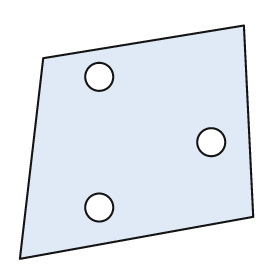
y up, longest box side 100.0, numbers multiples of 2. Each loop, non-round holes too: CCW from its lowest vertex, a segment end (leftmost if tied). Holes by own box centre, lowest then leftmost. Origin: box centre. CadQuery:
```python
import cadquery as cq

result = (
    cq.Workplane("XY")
    .moveTo(-50.0, -50.0)
    .lineTo(50.0, -32.0)
    .lineTo(46.0, 50.0)
    .lineTo(-40.0, 36.0)
    .close()
    .moveTo(-16.0, -28.0)
    .circle(6.0)
    .moveTo(32.0, 0.0)
    .circle(6.0)
    .moveTo(-16.0, 28.0)
    .circle(6.0)
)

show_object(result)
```